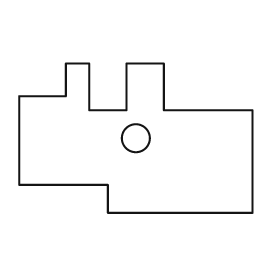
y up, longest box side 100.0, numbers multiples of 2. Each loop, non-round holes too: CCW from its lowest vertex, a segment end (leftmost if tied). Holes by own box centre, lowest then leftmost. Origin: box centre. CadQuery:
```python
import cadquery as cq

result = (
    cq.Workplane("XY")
    .moveTo(-12.0, -32.0)
    .lineTo(50.0, -32.0)
    .lineTo(50.0, 12.0)
    .lineTo(12.0, 12.0)
    .lineTo(12.0, 32.0)
    .lineTo(-4.0, 32.0)
    .lineTo(-4.0, 12.0)
    .lineTo(-20.0, 12.0)
    .lineTo(-20.0, 32.0)
    .lineTo(-30.0, 32.0)
    .lineTo(-30.0, 18.0)
    .lineTo(-50.0, 18.0)
    .lineTo(-50.0, -20.0)
    .lineTo(-12.0, -20.0)
    .close()
    .moveTo(0.0, 0.0)
    .circle(6.0)
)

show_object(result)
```